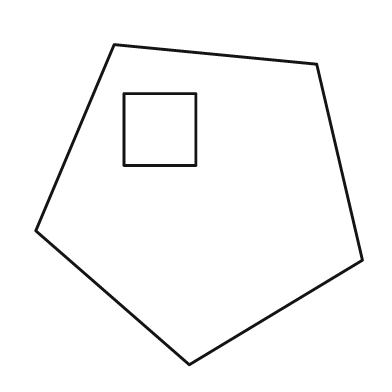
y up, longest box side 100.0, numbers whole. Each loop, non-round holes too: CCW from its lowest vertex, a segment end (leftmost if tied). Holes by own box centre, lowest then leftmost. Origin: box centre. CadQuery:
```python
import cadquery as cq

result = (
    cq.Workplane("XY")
    .moveTo(-3.0, -49.0)
    .lineTo(50.0, -17.0)
    .lineTo(36.0, 43.0)
    .lineTo(-26.0, 49.0)
    .lineTo(-50.0, -8.0)
    .close()
    .moveTo(-23.0, 12.0)
    .lineTo(-1.0, 12.0)
    .lineTo(-1.0, 34.0)
    .lineTo(-23.0, 34.0)
    .close()
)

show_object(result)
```